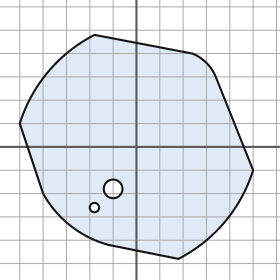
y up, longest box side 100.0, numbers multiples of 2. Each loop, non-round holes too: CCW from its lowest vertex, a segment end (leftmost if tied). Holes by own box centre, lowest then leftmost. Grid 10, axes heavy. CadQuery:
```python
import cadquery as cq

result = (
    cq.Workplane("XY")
    .moveTo(18.0, -48.0)
    .threePointArc((38.0, -32.0), (50.0, -10.0))
    .lineTo(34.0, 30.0)
    .threePointArc((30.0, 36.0), (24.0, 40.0))
    .lineTo(-18.0, 48.0)
    .threePointArc((-38.0, 32.0), (-50.0, 10.0))
    .lineTo(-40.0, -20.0)
    .threePointArc((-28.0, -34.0), (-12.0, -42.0))
    .close()
    .moveTo(-18.0, -26.0)
    .circle(2.0)
    .moveTo(-10.0, -18.0)
    .circle(4.0)
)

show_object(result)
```